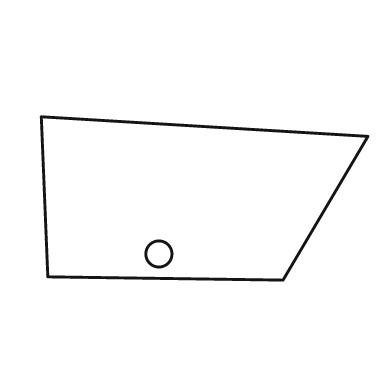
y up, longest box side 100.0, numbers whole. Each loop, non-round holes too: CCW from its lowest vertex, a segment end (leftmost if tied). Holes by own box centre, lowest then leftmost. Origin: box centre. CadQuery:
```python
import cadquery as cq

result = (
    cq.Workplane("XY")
    .moveTo(24.0, -25.0)
    .lineTo(50.0, 19.0)
    .lineTo(-50.0, 25.0)
    .lineTo(-48.0, -24.0)
    .close()
    .moveTo(-14.0, -17.0)
    .circle(4.0)
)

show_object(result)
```